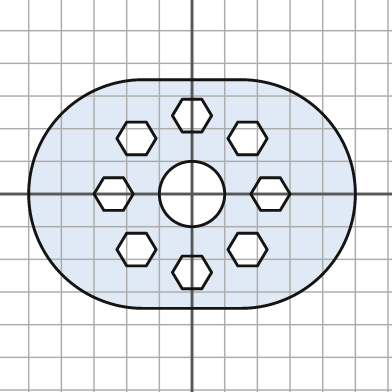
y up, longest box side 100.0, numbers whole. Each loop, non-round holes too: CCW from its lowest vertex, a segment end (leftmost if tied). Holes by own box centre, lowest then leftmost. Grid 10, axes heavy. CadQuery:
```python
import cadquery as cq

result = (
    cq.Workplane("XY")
    .moveTo(-15.0, -35.0)
    .lineTo(15.0, -35.0)
    .threePointArc((50.0, 0.0), (15.0, 35.0))
    .lineTo(-15.0, 35.0)
    .threePointArc((-50.0, 0.0), (-15.0, -35.0))
    .close()
    .moveTo(-3.0, -29.0)
    .lineTo(3.0, -29.0)
    .lineTo(6.0, -24.0)
    .lineTo(3.0, -19.0)
    .lineTo(-3.0, -19.0)
    .lineTo(-6.0, -24.0)
    .close()
    .moveTo(-20.0, -22.0)
    .lineTo(-14.0, -22.0)
    .lineTo(-11.0, -17.0)
    .lineTo(-14.0, -12.0)
    .lineTo(-20.0, -12.0)
    .lineTo(-23.0, -17.0)
    .close()
    .moveTo(14.0, -22.0)
    .lineTo(20.0, -22.0)
    .lineTo(23.0, -17.0)
    .lineTo(20.0, -12.0)
    .lineTo(14.0, -12.0)
    .lineTo(11.0, -17.0)
    .close()
    .moveTo(-27.0, -5.0)
    .lineTo(-21.0, -5.0)
    .lineTo(-18.0, 0.0)
    .lineTo(-21.0, 5.0)
    .lineTo(-27.0, 5.0)
    .lineTo(-30.0, 0.0)
    .close()
    .moveTo(0.0, 0.0)
    .circle(10.0)
    .moveTo(21.0, -5.0)
    .lineTo(27.0, -5.0)
    .lineTo(30.0, 0.0)
    .lineTo(27.0, 5.0)
    .lineTo(21.0, 5.0)
    .lineTo(18.0, 0.0)
    .close()
    .moveTo(-20.0, 12.0)
    .lineTo(-14.0, 12.0)
    .lineTo(-11.0, 17.0)
    .lineTo(-14.0, 22.0)
    .lineTo(-20.0, 22.0)
    .lineTo(-23.0, 17.0)
    .close()
    .moveTo(14.0, 12.0)
    .lineTo(20.0, 12.0)
    .lineTo(23.0, 17.0)
    .lineTo(20.0, 22.0)
    .lineTo(14.0, 22.0)
    .lineTo(11.0, 17.0)
    .close()
    .moveTo(-3.0, 19.0)
    .lineTo(3.0, 19.0)
    .lineTo(6.0, 24.0)
    .lineTo(3.0, 29.0)
    .lineTo(-3.0, 29.0)
    .lineTo(-6.0, 24.0)
    .close()
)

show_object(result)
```